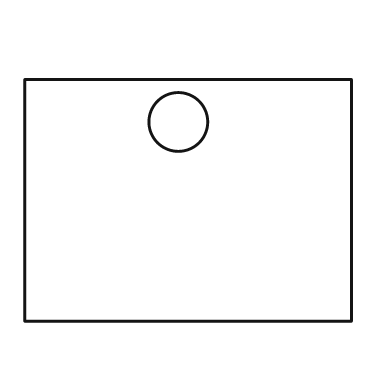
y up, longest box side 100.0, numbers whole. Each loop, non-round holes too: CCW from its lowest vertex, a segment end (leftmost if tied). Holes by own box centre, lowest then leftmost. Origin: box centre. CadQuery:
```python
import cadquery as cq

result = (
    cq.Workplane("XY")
    .moveTo(-50.0, -37.0)
    .lineTo(50.0, -37.0)
    .lineTo(50.0, 37.0)
    .lineTo(-50.0, 37.0)
    .close()
    .moveTo(-3.0, 24.0)
    .circle(9.0)
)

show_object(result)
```